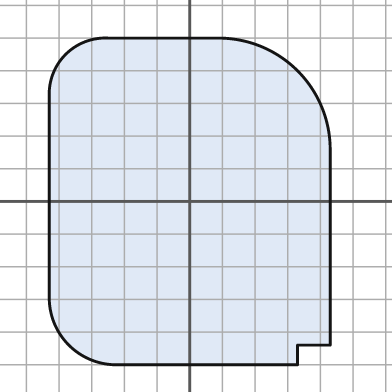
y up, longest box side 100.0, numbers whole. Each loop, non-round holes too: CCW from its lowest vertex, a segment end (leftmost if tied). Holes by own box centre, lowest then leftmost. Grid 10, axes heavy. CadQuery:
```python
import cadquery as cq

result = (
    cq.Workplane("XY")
    .moveTo(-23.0, -50.0)
    .lineTo(33.0, -50.0)
    .lineTo(33.0, -44.0)
    .lineTo(43.0, -44.0)
    .lineTo(43.0, 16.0)
    .threePointArc((33.0, 40.0), (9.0, 50.0))
    .lineTo(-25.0, 50.0)
    .threePointArc((-38.0, 45.0), (-43.0, 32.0))
    .lineTo(-43.0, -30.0)
    .threePointArc((-37.0, -44.0), (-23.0, -50.0))
    .close()
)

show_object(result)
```